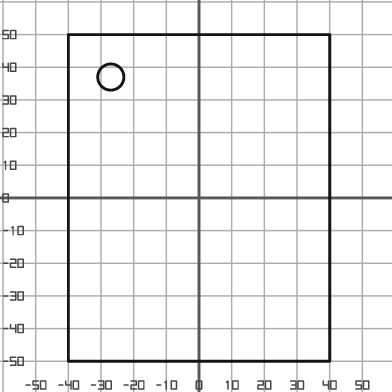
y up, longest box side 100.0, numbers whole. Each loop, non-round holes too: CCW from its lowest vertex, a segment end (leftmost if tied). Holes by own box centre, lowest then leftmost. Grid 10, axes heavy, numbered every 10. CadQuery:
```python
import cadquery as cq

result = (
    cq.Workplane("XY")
    .moveTo(-40.0, -50.0)
    .lineTo(40.0, -50.0)
    .lineTo(40.0, 50.0)
    .lineTo(-40.0, 50.0)
    .close()
    .moveTo(-27.0, 37.0)
    .circle(4.0)
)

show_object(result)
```